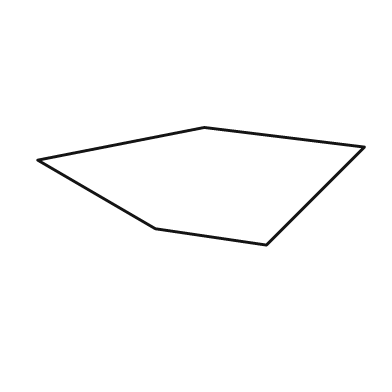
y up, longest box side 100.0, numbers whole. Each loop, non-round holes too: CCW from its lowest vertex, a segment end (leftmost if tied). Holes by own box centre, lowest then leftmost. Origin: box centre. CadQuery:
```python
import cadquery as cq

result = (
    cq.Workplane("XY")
    .moveTo(20.0, -18.0)
    .lineTo(50.0, 12.0)
    .lineTo(1.0, 18.0)
    .lineTo(-50.0, 8.0)
    .lineTo(-14.0, -13.0)
    .close()
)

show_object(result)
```